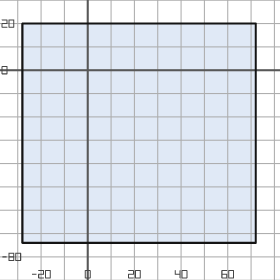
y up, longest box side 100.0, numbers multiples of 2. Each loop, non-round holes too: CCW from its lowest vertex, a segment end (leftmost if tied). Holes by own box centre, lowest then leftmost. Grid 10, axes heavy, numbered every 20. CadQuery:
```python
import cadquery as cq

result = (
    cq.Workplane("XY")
    .moveTo(-28.0, -74.0)
    .lineTo(72.0, -74.0)
    .lineTo(72.0, 20.0)
    .lineTo(-28.0, 20.0)
    .close()
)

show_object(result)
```